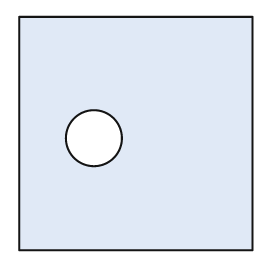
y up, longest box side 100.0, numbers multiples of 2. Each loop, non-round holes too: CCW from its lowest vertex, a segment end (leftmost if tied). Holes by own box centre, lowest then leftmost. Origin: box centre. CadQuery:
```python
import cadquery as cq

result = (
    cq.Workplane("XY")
    .moveTo(-50.0, -50.0)
    .lineTo(50.0, -50.0)
    .lineTo(50.0, 50.0)
    .lineTo(-50.0, 50.0)
    .close()
    .moveTo(-18.0, -2.0)
    .circle(12.0)
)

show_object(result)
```